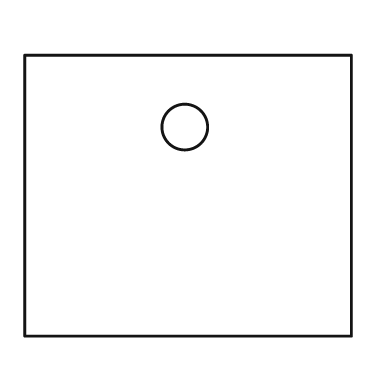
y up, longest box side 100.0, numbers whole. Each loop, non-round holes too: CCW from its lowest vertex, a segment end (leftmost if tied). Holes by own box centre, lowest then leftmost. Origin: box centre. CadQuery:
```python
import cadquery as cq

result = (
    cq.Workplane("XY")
    .moveTo(-50.0, -43.0)
    .lineTo(50.0, -43.0)
    .lineTo(50.0, 43.0)
    .lineTo(-50.0, 43.0)
    .close()
    .moveTo(-1.0, 21.0)
    .circle(7.0)
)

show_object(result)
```